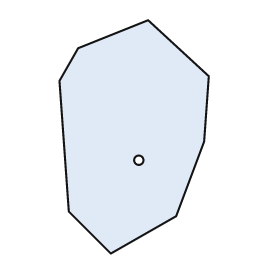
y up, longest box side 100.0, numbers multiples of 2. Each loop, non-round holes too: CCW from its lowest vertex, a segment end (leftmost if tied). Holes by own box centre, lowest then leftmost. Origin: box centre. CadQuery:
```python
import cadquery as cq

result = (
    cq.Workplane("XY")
    .moveTo(-10.0, -50.0)
    .lineTo(18.0, -34.0)
    .lineTo(30.0, -2.0)
    .lineTo(32.0, 26.0)
    .lineTo(6.0, 50.0)
    .lineTo(-24.0, 38.0)
    .lineTo(-32.0, 24.0)
    .lineTo(-28.0, -32.0)
    .close()
    .moveTo(2.0, -10.0)
    .circle(2.0)
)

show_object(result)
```